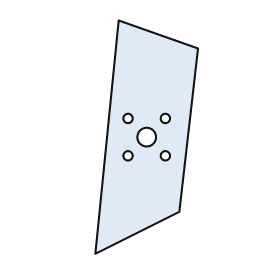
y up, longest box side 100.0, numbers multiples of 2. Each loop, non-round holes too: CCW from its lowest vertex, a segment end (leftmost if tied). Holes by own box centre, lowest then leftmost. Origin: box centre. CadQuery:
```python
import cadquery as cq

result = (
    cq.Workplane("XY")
    .moveTo(-22.0, -50.0)
    .lineTo(14.0, -32.0)
    .lineTo(22.0, 38.0)
    .lineTo(-12.0, 50.0)
    .close()
    .moveTo(-8.0, -8.0)
    .circle(2.0)
    .moveTo(8.0, -8.0)
    .circle(2.0)
    .moveTo(0.0, 0.0)
    .circle(4.0)
    .moveTo(-8.0, 8.0)
    .circle(2.0)
    .moveTo(8.0, 8.0)
    .circle(2.0)
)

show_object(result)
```